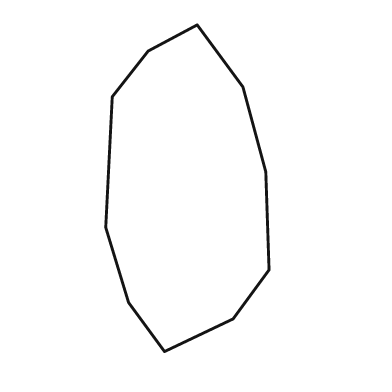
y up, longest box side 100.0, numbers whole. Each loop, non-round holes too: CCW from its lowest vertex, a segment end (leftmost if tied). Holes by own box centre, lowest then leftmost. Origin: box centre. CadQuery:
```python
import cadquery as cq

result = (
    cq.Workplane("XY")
    .moveTo(-7.0, -50.0)
    .lineTo(14.0, -40.0)
    .lineTo(25.0, -25.0)
    .lineTo(24.0, 5.0)
    .lineTo(17.0, 31.0)
    .lineTo(3.0, 50.0)
    .lineTo(-12.0, 42.0)
    .lineTo(-23.0, 28.0)
    .lineTo(-25.0, -12.0)
    .lineTo(-18.0, -35.0)
    .close()
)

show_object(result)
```